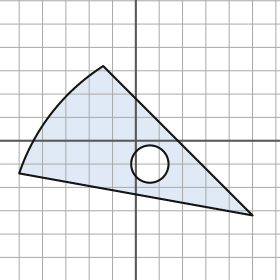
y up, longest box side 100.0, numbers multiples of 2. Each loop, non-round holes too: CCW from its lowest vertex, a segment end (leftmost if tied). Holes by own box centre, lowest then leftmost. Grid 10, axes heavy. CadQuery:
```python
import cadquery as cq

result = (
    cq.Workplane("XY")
    .moveTo(50.0, -32.0)
    .lineTo(-14.0, 32.0)
    .threePointArc((-36.0, 12.0), (-50.0, -14.0))
    .close()
    .moveTo(6.0, -10.0)
    .circle(8.0)
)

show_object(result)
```